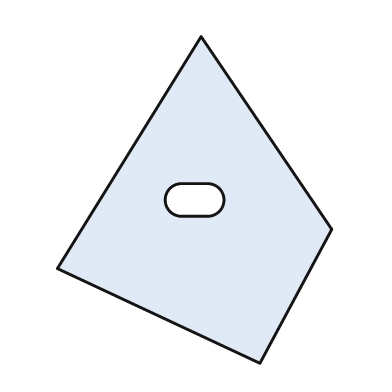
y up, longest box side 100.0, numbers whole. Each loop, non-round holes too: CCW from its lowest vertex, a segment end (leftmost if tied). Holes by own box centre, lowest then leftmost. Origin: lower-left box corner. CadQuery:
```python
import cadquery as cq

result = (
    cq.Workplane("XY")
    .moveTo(62.0, 0.0)
    .lineTo(84.0, 41.0)
    .lineTo(44.0, 100.0)
    .lineTo(0.0, 29.0)
    .close()
    .moveTo(38.0, 45.0)
    .lineTo(46.0, 45.0)
    .threePointArc((51.0, 50.0), (46.0, 55.0))
    .lineTo(38.0, 55.0)
    .threePointArc((33.0, 50.0), (38.0, 45.0))
    .close()
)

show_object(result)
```